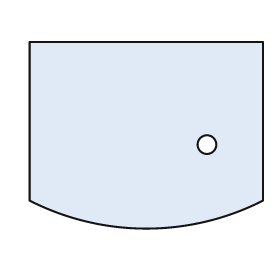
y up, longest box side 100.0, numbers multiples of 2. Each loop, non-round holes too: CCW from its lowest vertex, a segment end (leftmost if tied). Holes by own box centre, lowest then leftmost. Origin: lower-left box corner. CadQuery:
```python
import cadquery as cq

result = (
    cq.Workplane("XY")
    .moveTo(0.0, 12.0)
    .threePointArc((50.0, 0.0), (100.0, 12.0))
    .lineTo(100.0, 80.0)
    .lineTo(0.0, 80.0)
    .close()
    .moveTo(76.0, 36.0)
    .circle(4.0)
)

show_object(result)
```